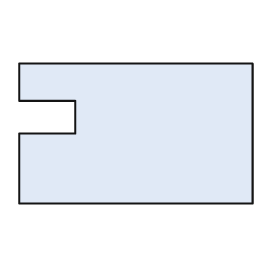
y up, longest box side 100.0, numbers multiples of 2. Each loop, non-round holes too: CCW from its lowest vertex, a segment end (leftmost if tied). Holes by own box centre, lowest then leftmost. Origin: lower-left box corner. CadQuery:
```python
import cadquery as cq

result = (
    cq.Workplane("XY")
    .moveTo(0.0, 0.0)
    .lineTo(100.0, 0.0)
    .lineTo(100.0, 60.0)
    .lineTo(0.0, 60.0)
    .lineTo(0.0, 44.0)
    .lineTo(24.0, 44.0)
    .lineTo(24.0, 30.0)
    .lineTo(0.0, 30.0)
    .close()
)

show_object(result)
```